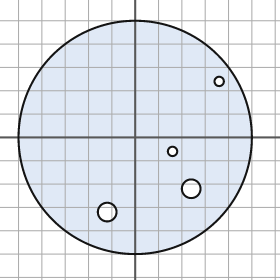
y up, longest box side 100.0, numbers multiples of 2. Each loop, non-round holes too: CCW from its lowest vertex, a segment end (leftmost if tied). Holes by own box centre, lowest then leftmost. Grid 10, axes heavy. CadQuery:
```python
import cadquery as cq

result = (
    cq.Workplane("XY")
    .moveTo(0.0, 0.0)
    .circle(50.0)
    .moveTo(-12.0, -32.0)
    .circle(4.0)
    .moveTo(24.0, -22.0)
    .circle(4.0)
    .moveTo(16.0, -6.0)
    .circle(2.0)
    .moveTo(36.0, 24.0)
    .circle(2.0)
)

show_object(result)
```